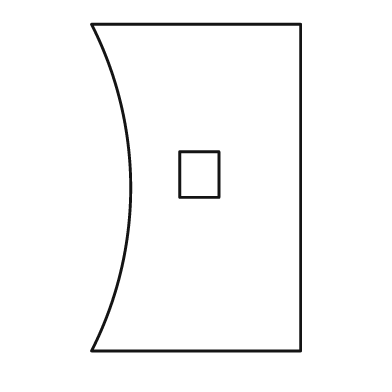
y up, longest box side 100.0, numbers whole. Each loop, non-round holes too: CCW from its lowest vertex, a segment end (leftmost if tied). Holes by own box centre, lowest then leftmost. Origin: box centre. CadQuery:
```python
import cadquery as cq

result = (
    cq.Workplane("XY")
    .moveTo(-32.0, -50.0)
    .lineTo(32.0, -50.0)
    .lineTo(32.0, 50.0)
    .lineTo(-32.0, 50.0)
    .threePointArc((-20.0, 0.0), (-32.0, -50.0))
    .close()
    .moveTo(-5.0, -3.0)
    .lineTo(7.0, -3.0)
    .lineTo(7.0, 11.0)
    .lineTo(-5.0, 11.0)
    .close()
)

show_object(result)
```